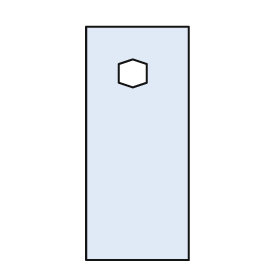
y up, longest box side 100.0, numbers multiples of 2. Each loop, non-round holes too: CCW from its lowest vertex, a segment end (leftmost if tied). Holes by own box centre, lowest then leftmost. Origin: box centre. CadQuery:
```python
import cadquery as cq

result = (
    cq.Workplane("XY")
    .moveTo(-22.0, -50.0)
    .lineTo(22.0, -50.0)
    .lineTo(22.0, 50.0)
    .lineTo(-22.0, 50.0)
    .close()
    .moveTo(-2.0, 24.0)
    .lineTo(4.0, 26.0)
    .lineTo(4.0, 34.0)
    .lineTo(-2.0, 36.0)
    .lineTo(-8.0, 34.0)
    .lineTo(-8.0, 26.0)
    .close()
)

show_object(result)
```